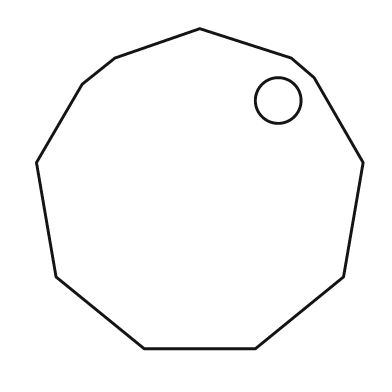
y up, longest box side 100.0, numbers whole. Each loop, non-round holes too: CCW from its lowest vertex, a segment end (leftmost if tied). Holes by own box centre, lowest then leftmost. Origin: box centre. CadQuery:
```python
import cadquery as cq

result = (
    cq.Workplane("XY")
    .moveTo(-17.0, -49.0)
    .lineTo(17.0, -49.0)
    .lineTo(44.0, -27.0)
    .lineTo(50.0, 8.0)
    .lineTo(35.0, 34.0)
    .lineTo(28.0, 40.0)
    .lineTo(0.0, 49.0)
    .lineTo(-26.0, 40.0)
    .lineTo(-36.0, 32.0)
    .lineTo(-50.0, 8.0)
    .lineTo(-44.0, -27.0)
    .close()
    .moveTo(24.0, 27.0)
    .circle(7.0)
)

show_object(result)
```